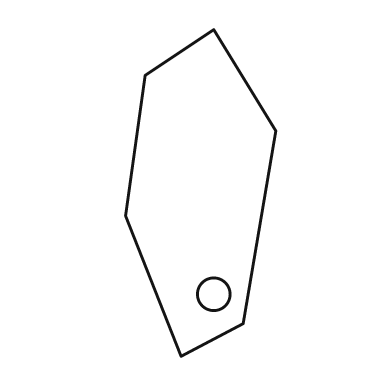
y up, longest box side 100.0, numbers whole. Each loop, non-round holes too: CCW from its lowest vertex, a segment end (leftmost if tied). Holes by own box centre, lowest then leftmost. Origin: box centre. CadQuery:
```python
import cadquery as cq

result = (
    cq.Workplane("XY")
    .moveTo(-6.0, -50.0)
    .lineTo(13.0, -40.0)
    .lineTo(23.0, 19.0)
    .lineTo(4.0, 50.0)
    .lineTo(-17.0, 36.0)
    .lineTo(-23.0, -7.0)
    .close()
    .moveTo(4.0, -31.0)
    .circle(5.0)
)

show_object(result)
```